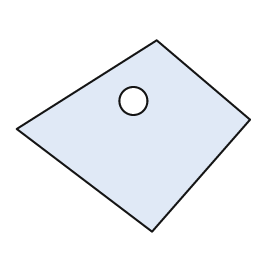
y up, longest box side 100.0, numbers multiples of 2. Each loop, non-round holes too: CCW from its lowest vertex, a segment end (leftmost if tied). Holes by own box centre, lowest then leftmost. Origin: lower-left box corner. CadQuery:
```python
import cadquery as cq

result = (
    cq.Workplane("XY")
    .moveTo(58.0, 0.0)
    .lineTo(100.0, 48.0)
    .lineTo(60.0, 82.0)
    .lineTo(0.0, 44.0)
    .close()
    .moveTo(50.0, 56.0)
    .circle(6.0)
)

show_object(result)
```